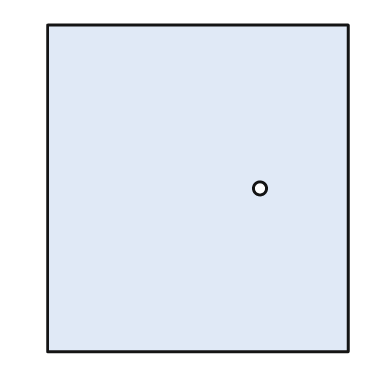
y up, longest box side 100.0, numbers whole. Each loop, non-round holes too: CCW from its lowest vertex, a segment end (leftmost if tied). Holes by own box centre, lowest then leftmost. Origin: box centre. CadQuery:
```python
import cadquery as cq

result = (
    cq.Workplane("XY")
    .moveTo(-46.0, -50.0)
    .lineTo(46.0, -50.0)
    .lineTo(46.0, 50.0)
    .lineTo(-46.0, 50.0)
    .close()
    .moveTo(19.0, 0.0)
    .circle(2.0)
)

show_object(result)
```